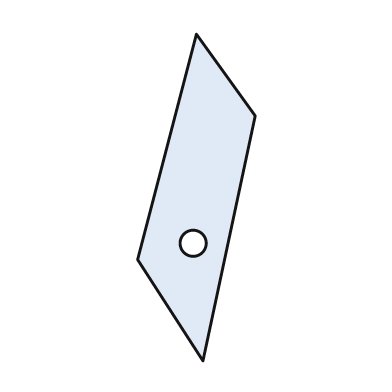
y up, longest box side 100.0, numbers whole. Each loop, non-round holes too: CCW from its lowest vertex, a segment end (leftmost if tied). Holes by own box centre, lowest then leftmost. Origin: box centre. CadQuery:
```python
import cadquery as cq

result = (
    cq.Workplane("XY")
    .moveTo(2.0, -50.0)
    .lineTo(18.0, 25.0)
    .lineTo(0.0, 50.0)
    .lineTo(-18.0, -19.0)
    .close()
    .moveTo(-1.0, -14.0)
    .circle(4.0)
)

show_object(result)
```